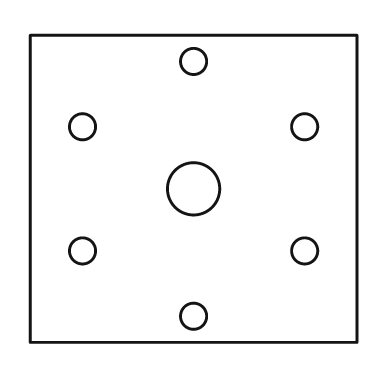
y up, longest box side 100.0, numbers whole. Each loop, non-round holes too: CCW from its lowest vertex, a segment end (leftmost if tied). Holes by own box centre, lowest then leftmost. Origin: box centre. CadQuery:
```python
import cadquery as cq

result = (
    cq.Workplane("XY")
    .moveTo(-50.0, -47.0)
    .lineTo(50.0, -47.0)
    .lineTo(50.0, 47.0)
    .lineTo(-50.0, 47.0)
    .close()
    .moveTo(0.0, -39.0)
    .circle(4.0)
    .moveTo(-34.0, -19.0)
    .circle(4.0)
    .moveTo(34.0, -19.0)
    .circle(4.0)
    .moveTo(0.0, 0.0)
    .circle(8.0)
    .moveTo(-34.0, 19.0)
    .circle(4.0)
    .moveTo(34.0, 19.0)
    .circle(4.0)
    .moveTo(0.0, 39.0)
    .circle(4.0)
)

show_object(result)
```